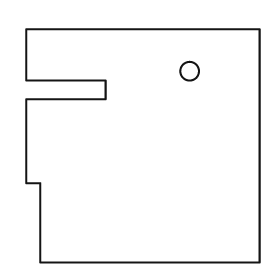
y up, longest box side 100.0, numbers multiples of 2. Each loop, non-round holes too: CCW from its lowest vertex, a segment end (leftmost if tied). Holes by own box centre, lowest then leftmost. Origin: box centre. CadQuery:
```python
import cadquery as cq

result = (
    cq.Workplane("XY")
    .moveTo(-44.0, -50.0)
    .lineTo(50.0, -50.0)
    .lineTo(50.0, 50.0)
    .lineTo(-50.0, 50.0)
    .lineTo(-50.0, 28.0)
    .lineTo(-16.0, 28.0)
    .lineTo(-16.0, 20.0)
    .lineTo(-50.0, 20.0)
    .lineTo(-50.0, -16.0)
    .lineTo(-44.0, -16.0)
    .close()
    .moveTo(20.0, 32.0)
    .circle(4.0)
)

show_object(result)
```